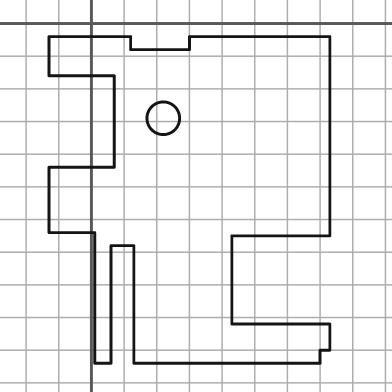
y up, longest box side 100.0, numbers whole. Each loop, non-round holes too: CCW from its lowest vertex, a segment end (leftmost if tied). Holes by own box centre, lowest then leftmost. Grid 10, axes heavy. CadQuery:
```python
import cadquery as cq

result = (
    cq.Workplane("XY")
    .moveTo(1.0, -104.0)
    .lineTo(6.0, -104.0)
    .lineTo(6.0, -68.0)
    .lineTo(13.0, -68.0)
    .lineTo(13.0, -104.0)
    .lineTo(70.0, -104.0)
    .lineTo(70.0, -100.0)
    .lineTo(73.0, -100.0)
    .lineTo(73.0, -92.0)
    .lineTo(43.0, -92.0)
    .lineTo(43.0, -65.0)
    .lineTo(73.0, -65.0)
    .lineTo(73.0, -4.0)
    .lineTo(30.0, -4.0)
    .lineTo(30.0, -8.0)
    .lineTo(12.0, -8.0)
    .lineTo(12.0, -4.0)
    .lineTo(-13.0, -4.0)
    .lineTo(-13.0, -16.0)
    .lineTo(7.0, -16.0)
    .lineTo(7.0, -44.0)
    .lineTo(-13.0, -44.0)
    .lineTo(-13.0, -64.0)
    .lineTo(1.0, -64.0)
    .close()
    .moveTo(22.0, -29.0)
    .circle(5.0)
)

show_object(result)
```